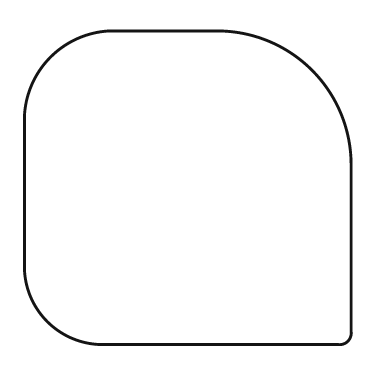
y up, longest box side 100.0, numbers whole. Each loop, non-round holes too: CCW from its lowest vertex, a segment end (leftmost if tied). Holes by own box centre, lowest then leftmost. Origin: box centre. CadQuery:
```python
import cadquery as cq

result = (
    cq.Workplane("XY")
    .moveTo(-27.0, -48.0)
    .lineTo(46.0, -48.0)
    .threePointArc((49.0, -47.0), (50.0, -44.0))
    .lineTo(50.0, 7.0)
    .threePointArc((38.0, 36.0), (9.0, 48.0))
    .lineTo(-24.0, 48.0)
    .threePointArc((-42.0, 40.0), (-50.0, 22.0))
    .lineTo(-50.0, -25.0)
    .threePointArc((-43.0, -41.0), (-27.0, -48.0))
    .close()
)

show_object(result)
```